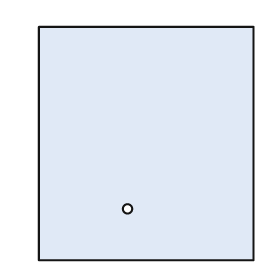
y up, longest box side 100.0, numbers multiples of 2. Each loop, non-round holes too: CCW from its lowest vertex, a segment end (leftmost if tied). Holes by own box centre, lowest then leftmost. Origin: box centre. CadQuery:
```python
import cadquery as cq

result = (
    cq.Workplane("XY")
    .moveTo(-46.0, -50.0)
    .lineTo(46.0, -50.0)
    .lineTo(46.0, 50.0)
    .lineTo(-46.0, 50.0)
    .close()
    .moveTo(-8.0, -28.0)
    .circle(2.0)
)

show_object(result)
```